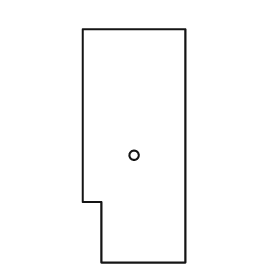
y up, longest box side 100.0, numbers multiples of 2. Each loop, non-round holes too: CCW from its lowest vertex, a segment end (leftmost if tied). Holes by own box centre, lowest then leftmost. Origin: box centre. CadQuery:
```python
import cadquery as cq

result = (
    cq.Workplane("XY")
    .moveTo(-14.0, -50.0)
    .lineTo(22.0, -50.0)
    .lineTo(22.0, 50.0)
    .lineTo(-22.0, 50.0)
    .lineTo(-22.0, -24.0)
    .lineTo(-14.0, -24.0)
    .close()
    .moveTo(0.0, -4.0)
    .circle(2.0)
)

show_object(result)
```